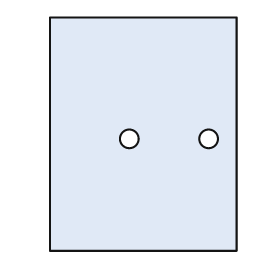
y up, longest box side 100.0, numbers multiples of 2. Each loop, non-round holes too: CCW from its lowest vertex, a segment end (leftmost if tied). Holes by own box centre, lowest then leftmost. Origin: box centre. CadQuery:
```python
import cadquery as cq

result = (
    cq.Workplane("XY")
    .moveTo(-40.0, -50.0)
    .lineTo(40.0, -50.0)
    .lineTo(40.0, 50.0)
    .lineTo(-40.0, 50.0)
    .close()
    .moveTo(-6.0, -2.0)
    .circle(4.0)
    .moveTo(28.0, -2.0)
    .circle(4.0)
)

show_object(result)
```